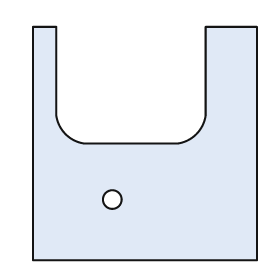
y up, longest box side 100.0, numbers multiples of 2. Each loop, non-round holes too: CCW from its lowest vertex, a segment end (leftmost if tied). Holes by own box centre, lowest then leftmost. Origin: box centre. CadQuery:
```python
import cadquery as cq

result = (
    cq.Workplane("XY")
    .moveTo(-48.0, -50.0)
    .lineTo(48.0, -50.0)
    .lineTo(48.0, 50.0)
    .lineTo(26.0, 50.0)
    .lineTo(26.0, 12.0)
    .threePointArc((22.0, 4.0), (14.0, 0.0))
    .lineTo(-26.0, 0.0)
    .threePointArc((-34.0, 4.0), (-38.0, 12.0))
    .lineTo(-38.0, 50.0)
    .lineTo(-48.0, 50.0)
    .close()
    .moveTo(-14.0, -24.0)
    .circle(4.0)
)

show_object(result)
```